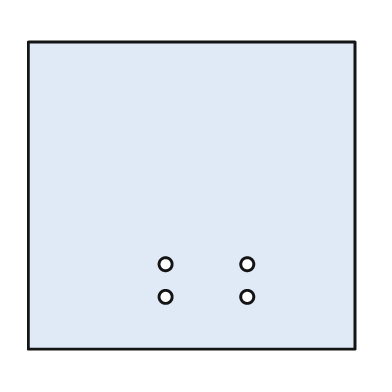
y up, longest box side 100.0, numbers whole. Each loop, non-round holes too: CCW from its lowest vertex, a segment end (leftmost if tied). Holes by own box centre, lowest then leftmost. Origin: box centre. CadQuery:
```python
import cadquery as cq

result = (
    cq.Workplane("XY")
    .moveTo(-50.0, -47.0)
    .lineTo(50.0, -47.0)
    .lineTo(50.0, 47.0)
    .lineTo(-50.0, 47.0)
    .close()
    .moveTo(-8.0, -31.0)
    .circle(2.0)
    .moveTo(17.0, -31.0)
    .circle(2.0)
    .moveTo(-8.0, -21.0)
    .circle(2.0)
    .moveTo(17.0, -21.0)
    .circle(2.0)
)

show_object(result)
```